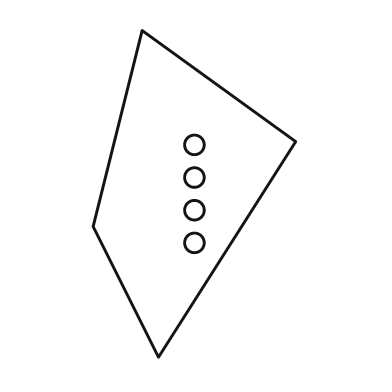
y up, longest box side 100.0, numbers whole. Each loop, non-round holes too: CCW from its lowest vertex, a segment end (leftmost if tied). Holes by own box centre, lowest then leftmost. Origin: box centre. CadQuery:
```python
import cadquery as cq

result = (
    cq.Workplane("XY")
    .moveTo(-11.0, -50.0)
    .lineTo(31.0, 16.0)
    .lineTo(-16.0, 50.0)
    .lineTo(-31.0, -10.0)
    .close()
    .moveTo(0.0, -15.0)
    .circle(3.0)
    .moveTo(0.0, -5.0)
    .circle(3.0)
    .moveTo(0.0, 5.0)
    .circle(3.0)
    .moveTo(0.0, 15.0)
    .circle(3.0)
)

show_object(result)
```